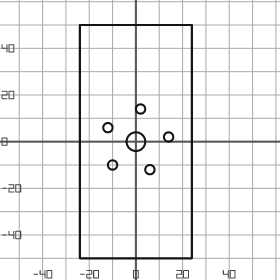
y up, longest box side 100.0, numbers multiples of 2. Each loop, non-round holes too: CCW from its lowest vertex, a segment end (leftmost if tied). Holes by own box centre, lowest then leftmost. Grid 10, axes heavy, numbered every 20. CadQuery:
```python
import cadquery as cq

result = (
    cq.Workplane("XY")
    .moveTo(-24.0, -50.0)
    .lineTo(24.0, -50.0)
    .lineTo(24.0, 50.0)
    .lineTo(-24.0, 50.0)
    .close()
    .moveTo(6.0, -12.0)
    .circle(2.0)
    .moveTo(-10.0, -10.0)
    .circle(2.0)
    .moveTo(0.0, 0.0)
    .circle(4.0)
    .moveTo(14.0, 2.0)
    .circle(2.0)
    .moveTo(-12.0, 6.0)
    .circle(2.0)
    .moveTo(2.0, 14.0)
    .circle(2.0)
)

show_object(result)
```